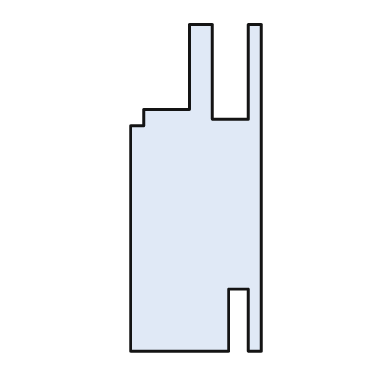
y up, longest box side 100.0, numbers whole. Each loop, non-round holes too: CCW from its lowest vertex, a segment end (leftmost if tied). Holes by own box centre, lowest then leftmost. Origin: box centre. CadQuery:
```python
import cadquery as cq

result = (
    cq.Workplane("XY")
    .moveTo(-20.0, -50.0)
    .lineTo(10.0, -50.0)
    .lineTo(10.0, -31.0)
    .lineTo(16.0, -31.0)
    .lineTo(16.0, -50.0)
    .lineTo(20.0, -50.0)
    .lineTo(20.0, 50.0)
    .lineTo(16.0, 50.0)
    .lineTo(16.0, 21.0)
    .lineTo(5.0, 21.0)
    .lineTo(5.0, 50.0)
    .lineTo(-2.0, 50.0)
    .lineTo(-2.0, 24.0)
    .lineTo(-16.0, 24.0)
    .lineTo(-16.0, 19.0)
    .lineTo(-20.0, 19.0)
    .close()
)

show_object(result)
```